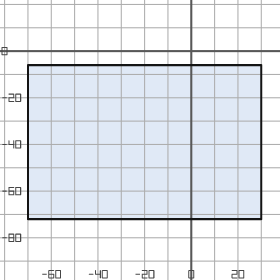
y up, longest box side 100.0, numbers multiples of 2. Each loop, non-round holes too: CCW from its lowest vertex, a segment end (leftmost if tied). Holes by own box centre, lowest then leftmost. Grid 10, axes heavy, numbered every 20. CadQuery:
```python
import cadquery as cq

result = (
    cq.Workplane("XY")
    .moveTo(-70.0, -72.0)
    .lineTo(30.0, -72.0)
    .lineTo(30.0, -6.0)
    .lineTo(-70.0, -6.0)
    .close()
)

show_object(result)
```